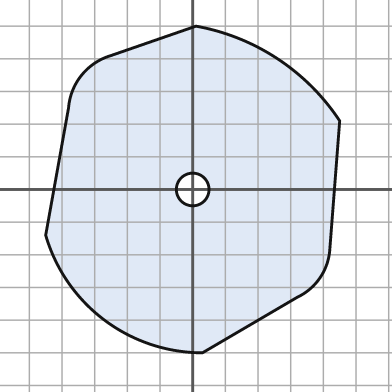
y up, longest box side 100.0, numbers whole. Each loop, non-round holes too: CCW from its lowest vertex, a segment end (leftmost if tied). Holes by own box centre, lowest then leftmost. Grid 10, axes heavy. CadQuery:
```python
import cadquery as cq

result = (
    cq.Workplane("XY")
    .moveTo(3.0, -50.0)
    .lineTo(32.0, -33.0)
    .threePointArc((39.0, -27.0), (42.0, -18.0))
    .lineTo(45.0, 21.0)
    .threePointArc((26.0, 40.0), (1.0, 50.0))
    .lineTo(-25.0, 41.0)
    .threePointArc((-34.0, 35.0), (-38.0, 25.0))
    .lineTo(-45.0, -14.0)
    .threePointArc((-27.0, -40.0), (3.0, -50.0))
    .close()
    .moveTo(0.0, 0.0)
    .circle(5.0)
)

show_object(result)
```